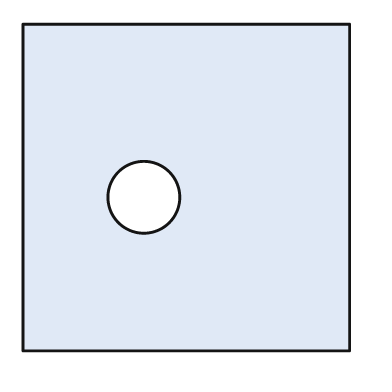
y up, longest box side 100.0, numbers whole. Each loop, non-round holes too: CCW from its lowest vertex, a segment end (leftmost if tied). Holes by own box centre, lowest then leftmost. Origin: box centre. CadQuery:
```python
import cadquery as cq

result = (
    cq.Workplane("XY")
    .moveTo(-50.0, -50.0)
    .lineTo(50.0, -50.0)
    .lineTo(50.0, 50.0)
    .lineTo(-50.0, 50.0)
    .close()
    .moveTo(-13.0, -3.0)
    .circle(11.0)
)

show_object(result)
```